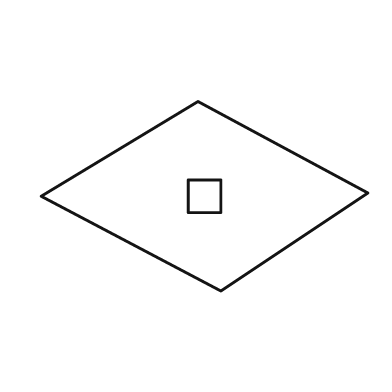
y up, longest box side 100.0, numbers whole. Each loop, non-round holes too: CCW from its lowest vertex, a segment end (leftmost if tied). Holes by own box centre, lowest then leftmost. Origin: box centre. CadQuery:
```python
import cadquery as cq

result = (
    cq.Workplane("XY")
    .moveTo(5.0, -29.0)
    .lineTo(50.0, 1.0)
    .lineTo(-2.0, 29.0)
    .lineTo(-50.0, 0.0)
    .close()
    .moveTo(-5.0, -5.0)
    .lineTo(5.0, -5.0)
    .lineTo(5.0, 5.0)
    .lineTo(-5.0, 5.0)
    .close()
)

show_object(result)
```